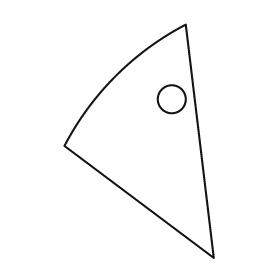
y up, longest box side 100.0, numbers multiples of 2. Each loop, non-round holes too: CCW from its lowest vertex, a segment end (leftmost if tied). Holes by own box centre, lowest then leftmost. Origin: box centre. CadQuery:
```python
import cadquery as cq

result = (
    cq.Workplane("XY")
    .moveTo(32.0, -50.0)
    .lineTo(20.0, 50.0)
    .threePointArc((-10.0, 28.0), (-32.0, -2.0))
    .close()
    .moveTo(14.0, 18.0)
    .circle(6.0)
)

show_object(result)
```